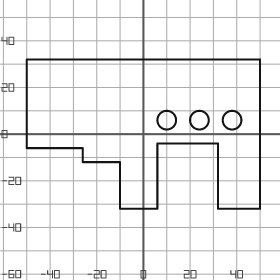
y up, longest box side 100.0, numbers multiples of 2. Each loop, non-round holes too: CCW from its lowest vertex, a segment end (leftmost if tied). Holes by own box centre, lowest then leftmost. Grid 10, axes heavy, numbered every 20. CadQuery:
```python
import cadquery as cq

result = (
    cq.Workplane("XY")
    .moveTo(-10.0, -32.0)
    .lineTo(6.0, -32.0)
    .lineTo(6.0, -4.0)
    .lineTo(32.0, -4.0)
    .lineTo(32.0, -32.0)
    .lineTo(50.0, -32.0)
    .lineTo(50.0, 32.0)
    .lineTo(-50.0, 32.0)
    .lineTo(-50.0, -6.0)
    .lineTo(-26.0, -6.0)
    .lineTo(-26.0, -12.0)
    .lineTo(-10.0, -12.0)
    .close()
    .moveTo(10.0, 6.0)
    .circle(4.0)
    .moveTo(24.0, 6.0)
    .circle(4.0)
    .moveTo(38.0, 6.0)
    .circle(4.0)
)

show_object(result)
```